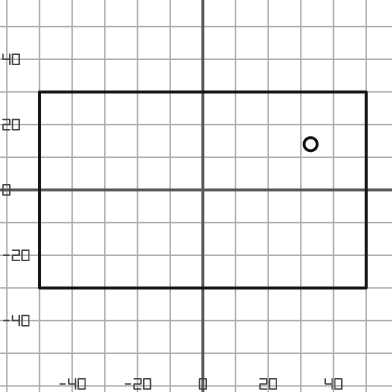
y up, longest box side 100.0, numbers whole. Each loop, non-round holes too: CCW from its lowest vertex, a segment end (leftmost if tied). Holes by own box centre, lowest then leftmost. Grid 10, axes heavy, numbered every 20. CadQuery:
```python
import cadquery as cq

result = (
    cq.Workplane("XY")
    .moveTo(-50.0, -30.0)
    .lineTo(50.0, -30.0)
    .lineTo(50.0, 30.0)
    .lineTo(-50.0, 30.0)
    .close()
    .moveTo(33.0, 14.0)
    .circle(2.0)
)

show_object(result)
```